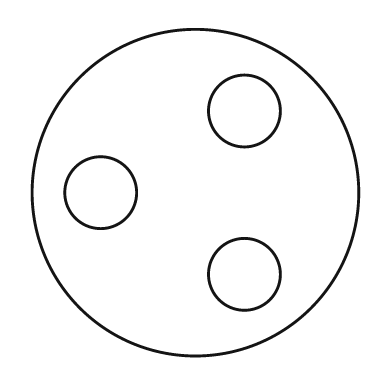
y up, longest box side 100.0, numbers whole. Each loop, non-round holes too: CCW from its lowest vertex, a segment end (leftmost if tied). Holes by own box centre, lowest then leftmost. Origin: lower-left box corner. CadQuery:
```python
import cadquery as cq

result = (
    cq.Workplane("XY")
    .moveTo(50.0, 50.0)
    .circle(50.0)
    .moveTo(65.0, 25.0)
    .circle(11.0)
    .moveTo(21.0, 50.0)
    .circle(11.0)
    .moveTo(65.0, 75.0)
    .circle(11.0)
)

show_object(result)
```